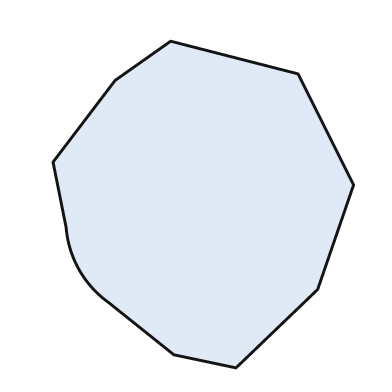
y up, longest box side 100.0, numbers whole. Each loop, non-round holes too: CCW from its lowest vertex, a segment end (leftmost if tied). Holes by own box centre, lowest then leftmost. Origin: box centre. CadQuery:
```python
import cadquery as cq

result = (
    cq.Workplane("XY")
    .moveTo(10.0, -50.0)
    .lineTo(35.0, -26.0)
    .lineTo(46.0, 6.0)
    .lineTo(29.0, 40.0)
    .lineTo(-10.0, 50.0)
    .lineTo(-27.0, 38.0)
    .lineTo(-46.0, 13.0)
    .lineTo(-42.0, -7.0)
    .threePointArc((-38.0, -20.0), (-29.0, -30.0))
    .lineTo(-9.0, -46.0)
    .close()
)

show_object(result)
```